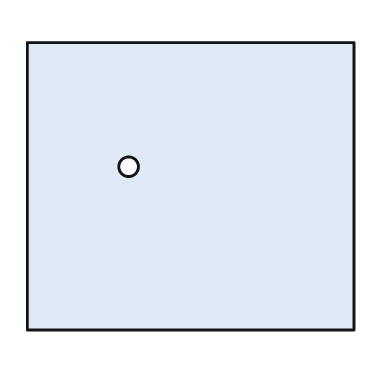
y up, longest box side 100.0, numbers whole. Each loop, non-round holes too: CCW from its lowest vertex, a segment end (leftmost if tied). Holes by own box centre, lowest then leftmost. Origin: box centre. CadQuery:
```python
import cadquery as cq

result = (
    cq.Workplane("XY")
    .moveTo(-50.0, -44.0)
    .lineTo(50.0, -44.0)
    .lineTo(50.0, 44.0)
    .lineTo(-50.0, 44.0)
    .close()
    .moveTo(-19.0, 6.0)
    .circle(3.0)
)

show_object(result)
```